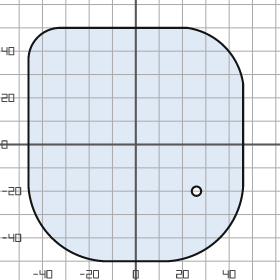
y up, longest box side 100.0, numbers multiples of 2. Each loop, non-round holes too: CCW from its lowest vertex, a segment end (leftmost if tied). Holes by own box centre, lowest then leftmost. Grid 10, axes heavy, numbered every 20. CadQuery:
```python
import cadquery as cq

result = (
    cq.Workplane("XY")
    .moveTo(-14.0, -50.0)
    .lineTo(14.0, -50.0)
    .threePointArc((36.0, -40.0), (46.0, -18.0))
    .lineTo(46.0, 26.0)
    .threePointArc((38.0, 42.0), (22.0, 50.0))
    .lineTo(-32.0, 50.0)
    .threePointArc((-42.0, 46.0), (-46.0, 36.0))
    .lineTo(-46.0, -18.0)
    .threePointArc((-36.0, -40.0), (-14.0, -50.0))
    .close()
    .moveTo(26.0, -20.0)
    .circle(2.0)
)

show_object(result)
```